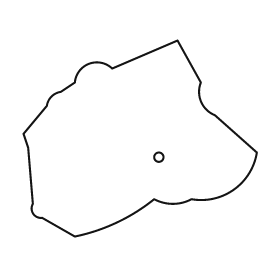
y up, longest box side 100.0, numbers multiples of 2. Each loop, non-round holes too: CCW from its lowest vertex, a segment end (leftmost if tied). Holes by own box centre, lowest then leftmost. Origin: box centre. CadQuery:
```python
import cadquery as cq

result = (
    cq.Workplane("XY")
    .moveTo(-28.0, -42.0)
    .threePointArc((-10.0, -36.0), (6.0, -26.0))
    .threePointArc((14.0, -28.0), (22.0, -26.0))
    .threePointArc((40.0, -22.0), (50.0, -6.0))
    .lineTo(32.0, 10.0)
    .threePointArc((26.0, 16.0), (26.0, 24.0))
    .lineTo(16.0, 42.0)
    .lineTo(-12.0, 30.0)
    .threePointArc((-22.0, 32.0), (-28.0, 24.0))
    .lineTo(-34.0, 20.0)
    .threePointArc((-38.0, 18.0), (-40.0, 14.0))
    .lineTo(-50.0, 2.0)
    .lineTo(-48.0, -4.0)
    .lineTo(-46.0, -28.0)
    .threePointArc((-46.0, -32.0), (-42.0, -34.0))
    .close()
    .moveTo(8.0, -8.0)
    .circle(2.0)
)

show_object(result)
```